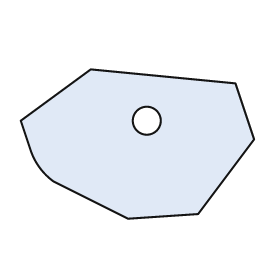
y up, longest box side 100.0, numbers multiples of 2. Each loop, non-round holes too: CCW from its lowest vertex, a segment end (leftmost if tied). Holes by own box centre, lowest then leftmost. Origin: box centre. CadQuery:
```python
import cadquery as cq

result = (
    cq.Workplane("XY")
    .moveTo(-4.0, -32.0)
    .lineTo(26.0, -30.0)
    .lineTo(50.0, 2.0)
    .lineTo(42.0, 26.0)
    .lineTo(-20.0, 32.0)
    .lineTo(-50.0, 10.0)
    .lineTo(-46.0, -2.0)
    .threePointArc((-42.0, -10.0), (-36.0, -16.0))
    .close()
    .moveTo(4.0, 10.0)
    .circle(6.0)
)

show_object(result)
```